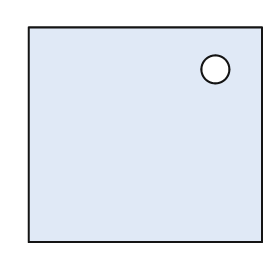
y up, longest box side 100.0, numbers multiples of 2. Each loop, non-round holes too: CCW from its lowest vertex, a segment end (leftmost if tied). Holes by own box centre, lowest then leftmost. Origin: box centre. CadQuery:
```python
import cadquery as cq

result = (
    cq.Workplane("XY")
    .moveTo(-50.0, -46.0)
    .lineTo(50.0, -46.0)
    .lineTo(50.0, 46.0)
    .lineTo(-50.0, 46.0)
    .close()
    .moveTo(30.0, 28.0)
    .circle(6.0)
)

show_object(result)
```